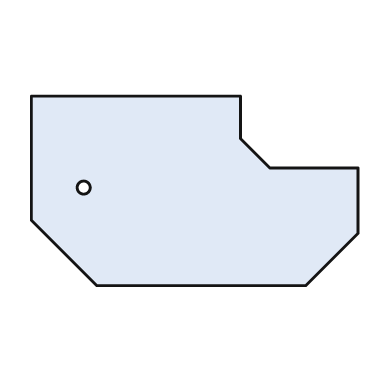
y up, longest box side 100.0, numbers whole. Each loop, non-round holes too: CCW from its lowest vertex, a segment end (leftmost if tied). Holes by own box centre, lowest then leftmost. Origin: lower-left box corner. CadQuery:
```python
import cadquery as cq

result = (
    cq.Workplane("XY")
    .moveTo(20.0, 0.0)
    .lineTo(84.0, 0.0)
    .lineTo(100.0, 16.0)
    .lineTo(100.0, 36.0)
    .lineTo(73.0, 36.0)
    .lineTo(64.0, 45.0)
    .lineTo(64.0, 58.0)
    .lineTo(0.0, 58.0)
    .lineTo(0.0, 20.0)
    .close()
    .moveTo(16.0, 30.0)
    .circle(2.0)
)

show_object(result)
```